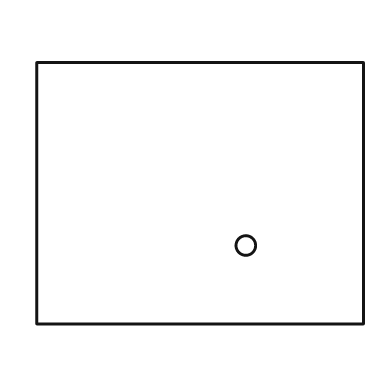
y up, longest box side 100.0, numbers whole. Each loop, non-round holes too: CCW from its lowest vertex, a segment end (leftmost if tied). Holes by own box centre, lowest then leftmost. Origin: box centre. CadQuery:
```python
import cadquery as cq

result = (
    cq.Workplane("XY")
    .moveTo(-50.0, -40.0)
    .lineTo(50.0, -40.0)
    .lineTo(50.0, 40.0)
    .lineTo(-50.0, 40.0)
    .close()
    .moveTo(14.0, -16.0)
    .circle(3.0)
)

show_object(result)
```